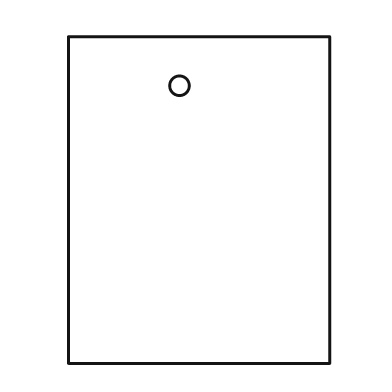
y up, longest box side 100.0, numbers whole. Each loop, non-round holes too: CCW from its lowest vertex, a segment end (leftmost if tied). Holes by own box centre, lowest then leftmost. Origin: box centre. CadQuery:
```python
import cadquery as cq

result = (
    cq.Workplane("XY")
    .moveTo(-40.0, -50.0)
    .lineTo(40.0, -50.0)
    .lineTo(40.0, 50.0)
    .lineTo(-40.0, 50.0)
    .close()
    .moveTo(-6.0, 35.0)
    .circle(3.0)
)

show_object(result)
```